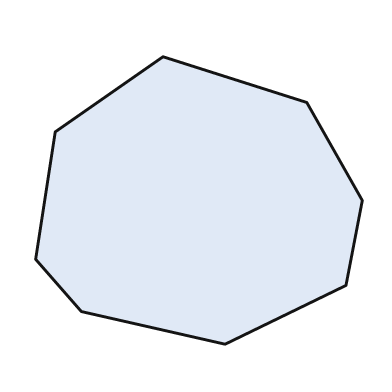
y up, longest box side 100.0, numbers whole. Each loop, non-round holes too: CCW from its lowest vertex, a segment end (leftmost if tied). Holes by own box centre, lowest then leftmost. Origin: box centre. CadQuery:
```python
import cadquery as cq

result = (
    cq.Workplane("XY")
    .moveTo(8.0, -44.0)
    .lineTo(45.0, -26.0)
    .lineTo(50.0, 0.0)
    .lineTo(33.0, 30.0)
    .lineTo(-11.0, 44.0)
    .lineTo(-44.0, 21.0)
    .lineTo(-50.0, -18.0)
    .lineTo(-36.0, -34.0)
    .close()
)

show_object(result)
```